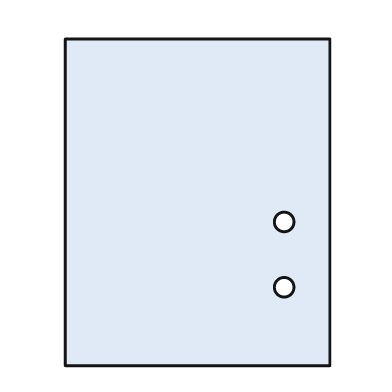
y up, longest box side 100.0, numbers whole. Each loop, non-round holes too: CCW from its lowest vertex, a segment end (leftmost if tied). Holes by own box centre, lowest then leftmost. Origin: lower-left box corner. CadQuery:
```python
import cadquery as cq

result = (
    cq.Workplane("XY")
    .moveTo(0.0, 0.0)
    .lineTo(81.0, 0.0)
    .lineTo(81.0, 100.0)
    .lineTo(0.0, 100.0)
    .close()
    .moveTo(67.0, 24.0)
    .circle(3.0)
    .moveTo(67.0, 44.0)
    .circle(3.0)
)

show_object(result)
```